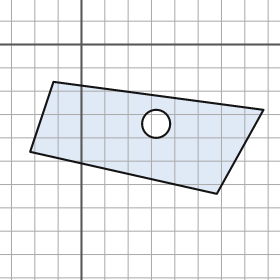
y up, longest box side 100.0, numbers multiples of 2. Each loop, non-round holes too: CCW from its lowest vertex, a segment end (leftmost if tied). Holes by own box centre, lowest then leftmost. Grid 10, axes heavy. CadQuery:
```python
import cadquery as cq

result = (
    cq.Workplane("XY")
    .moveTo(58.0, -64.0)
    .lineTo(78.0, -28.0)
    .lineTo(-12.0, -16.0)
    .lineTo(-22.0, -46.0)
    .close()
    .moveTo(32.0, -34.0)
    .circle(6.0)
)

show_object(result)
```